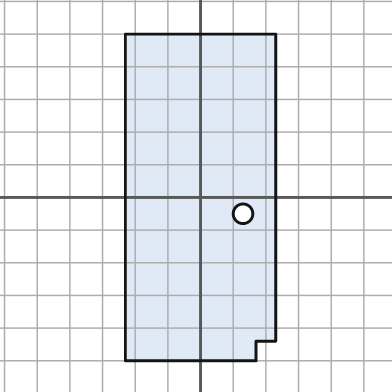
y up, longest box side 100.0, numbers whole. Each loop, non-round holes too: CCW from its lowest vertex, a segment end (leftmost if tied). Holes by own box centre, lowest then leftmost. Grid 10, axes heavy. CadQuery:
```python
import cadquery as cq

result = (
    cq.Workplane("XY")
    .moveTo(-23.0, -50.0)
    .lineTo(17.0, -50.0)
    .lineTo(17.0, -44.0)
    .lineTo(23.0, -44.0)
    .lineTo(23.0, 50.0)
    .lineTo(-23.0, 50.0)
    .close()
    .moveTo(13.0, -5.0)
    .circle(3.0)
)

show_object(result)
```